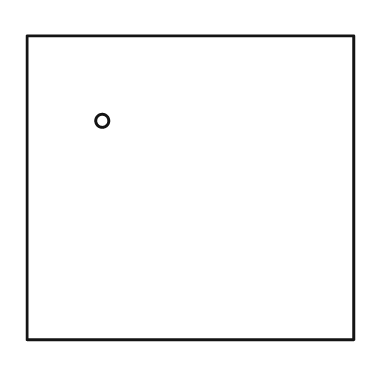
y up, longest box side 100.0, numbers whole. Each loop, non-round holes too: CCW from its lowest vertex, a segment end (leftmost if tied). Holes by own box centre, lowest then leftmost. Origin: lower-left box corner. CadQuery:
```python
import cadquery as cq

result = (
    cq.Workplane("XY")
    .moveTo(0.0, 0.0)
    .lineTo(100.0, 0.0)
    .lineTo(100.0, 93.0)
    .lineTo(0.0, 93.0)
    .close()
    .moveTo(23.0, 67.0)
    .circle(2.0)
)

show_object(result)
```